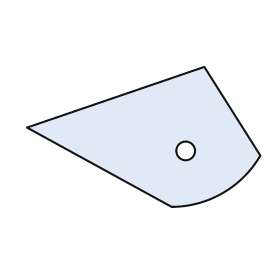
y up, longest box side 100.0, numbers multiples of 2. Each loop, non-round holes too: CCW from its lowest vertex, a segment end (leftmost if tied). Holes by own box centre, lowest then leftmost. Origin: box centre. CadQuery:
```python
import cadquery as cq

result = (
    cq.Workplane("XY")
    .moveTo(12.0, -30.0)
    .threePointArc((34.0, -24.0), (50.0, -8.0))
    .lineTo(26.0, 30.0)
    .lineTo(-50.0, 4.0)
    .close()
    .moveTo(18.0, -6.0)
    .circle(4.0)
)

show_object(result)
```